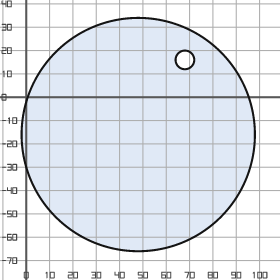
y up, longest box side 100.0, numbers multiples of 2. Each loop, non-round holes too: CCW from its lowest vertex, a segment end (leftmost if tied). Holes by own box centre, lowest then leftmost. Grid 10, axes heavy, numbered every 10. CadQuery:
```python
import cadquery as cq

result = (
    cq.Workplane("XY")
    .moveTo(48.0, -16.0)
    .circle(50.0)
    .moveTo(68.0, 16.0)
    .circle(4.0)
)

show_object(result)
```